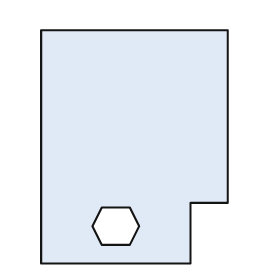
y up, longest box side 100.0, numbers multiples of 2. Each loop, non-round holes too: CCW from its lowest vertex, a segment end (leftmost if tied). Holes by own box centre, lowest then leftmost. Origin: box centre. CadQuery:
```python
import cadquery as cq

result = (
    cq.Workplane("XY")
    .moveTo(-40.0, -50.0)
    .lineTo(24.0, -50.0)
    .lineTo(24.0, -24.0)
    .lineTo(40.0, -24.0)
    .lineTo(40.0, 50.0)
    .lineTo(-40.0, 50.0)
    .close()
    .moveTo(-14.0, -42.0)
    .lineTo(-2.0, -42.0)
    .lineTo(2.0, -34.0)
    .lineTo(-2.0, -26.0)
    .lineTo(-14.0, -26.0)
    .lineTo(-18.0, -34.0)
    .close()
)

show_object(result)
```